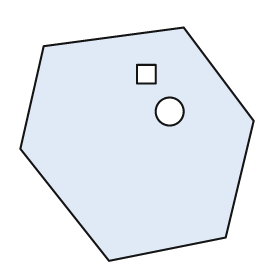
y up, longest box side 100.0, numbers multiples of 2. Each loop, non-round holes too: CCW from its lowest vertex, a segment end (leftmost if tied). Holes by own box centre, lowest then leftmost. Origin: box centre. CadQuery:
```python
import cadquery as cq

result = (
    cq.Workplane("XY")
    .moveTo(-12.0, -50.0)
    .lineTo(38.0, -40.0)
    .lineTo(50.0, 10.0)
    .lineTo(20.0, 50.0)
    .lineTo(-40.0, 42.0)
    .lineTo(-50.0, -2.0)
    .close()
    .moveTo(14.0, 14.0)
    .circle(6.0)
    .moveTo(0.0, 26.0)
    .lineTo(8.0, 26.0)
    .lineTo(8.0, 34.0)
    .lineTo(0.0, 34.0)
    .close()
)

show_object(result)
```